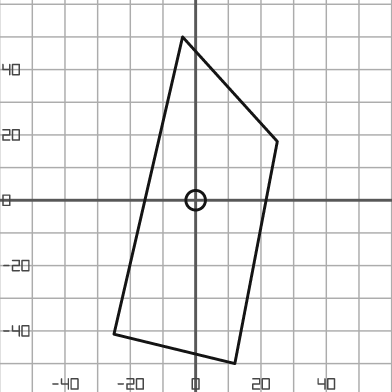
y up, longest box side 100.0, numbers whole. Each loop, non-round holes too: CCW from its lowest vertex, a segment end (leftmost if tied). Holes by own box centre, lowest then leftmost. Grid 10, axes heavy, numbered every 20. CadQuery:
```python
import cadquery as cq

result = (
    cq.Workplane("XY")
    .moveTo(12.0, -50.0)
    .lineTo(25.0, 18.0)
    .lineTo(-4.0, 50.0)
    .lineTo(-25.0, -41.0)
    .close()
    .moveTo(0.0, 0.0)
    .circle(3.0)
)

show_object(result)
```